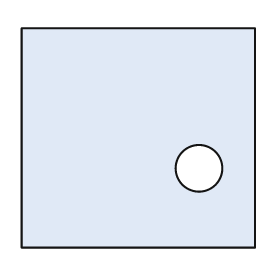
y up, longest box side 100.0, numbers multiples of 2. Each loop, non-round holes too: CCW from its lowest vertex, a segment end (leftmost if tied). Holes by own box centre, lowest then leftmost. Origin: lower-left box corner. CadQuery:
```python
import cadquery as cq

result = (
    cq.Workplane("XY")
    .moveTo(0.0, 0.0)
    .lineTo(100.0, 0.0)
    .lineTo(100.0, 94.0)
    .lineTo(0.0, 94.0)
    .close()
    .moveTo(76.0, 34.0)
    .circle(10.0)
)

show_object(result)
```